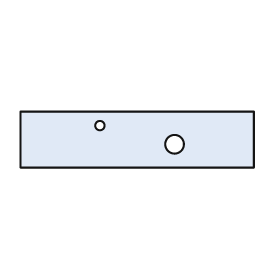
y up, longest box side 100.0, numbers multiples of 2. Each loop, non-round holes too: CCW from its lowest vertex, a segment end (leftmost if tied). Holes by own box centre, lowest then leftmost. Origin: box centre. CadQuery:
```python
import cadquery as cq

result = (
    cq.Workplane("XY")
    .moveTo(-50.0, -12.0)
    .lineTo(50.0, -12.0)
    .lineTo(50.0, 12.0)
    .lineTo(-50.0, 12.0)
    .close()
    .moveTo(16.0, -2.0)
    .circle(4.0)
    .moveTo(-16.0, 6.0)
    .circle(2.0)
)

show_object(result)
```